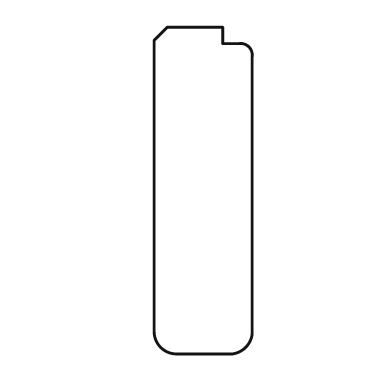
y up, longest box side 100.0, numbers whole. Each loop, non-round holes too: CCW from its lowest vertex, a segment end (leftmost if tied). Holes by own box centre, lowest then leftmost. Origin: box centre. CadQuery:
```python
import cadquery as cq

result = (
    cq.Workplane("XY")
    .moveTo(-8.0, -50.0)
    .lineTo(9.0, -50.0)
    .threePointArc((13.0, -48.0), (15.0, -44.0))
    .lineTo(15.0, 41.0)
    .threePointArc((14.0, 44.0), (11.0, 45.0))
    .lineTo(6.0, 45.0)
    .lineTo(6.0, 50.0)
    .lineTo(-11.0, 50.0)
    .lineTo(-15.0, 46.0)
    .lineTo(-15.0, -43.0)
    .threePointArc((-13.0, -48.0), (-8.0, -50.0))
    .close()
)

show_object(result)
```